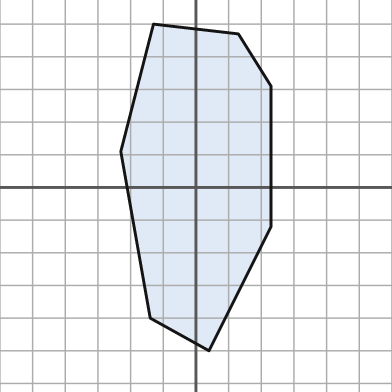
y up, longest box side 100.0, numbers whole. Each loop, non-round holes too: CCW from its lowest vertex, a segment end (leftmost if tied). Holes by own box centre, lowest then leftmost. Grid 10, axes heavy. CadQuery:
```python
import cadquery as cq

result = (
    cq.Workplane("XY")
    .moveTo(4.0, -50.0)
    .lineTo(23.0, -12.0)
    .lineTo(23.0, 31.0)
    .lineTo(13.0, 47.0)
    .lineTo(-13.0, 50.0)
    .lineTo(-23.0, 11.0)
    .lineTo(-14.0, -40.0)
    .close()
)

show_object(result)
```